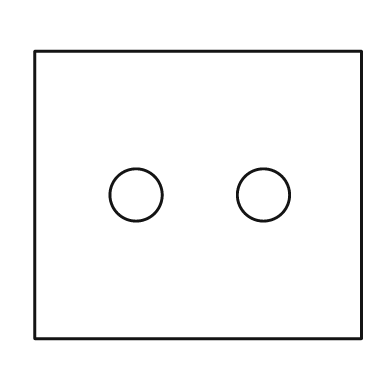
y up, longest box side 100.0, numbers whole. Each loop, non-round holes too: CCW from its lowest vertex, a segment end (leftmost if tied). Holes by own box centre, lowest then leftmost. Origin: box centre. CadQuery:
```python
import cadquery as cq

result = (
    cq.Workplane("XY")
    .moveTo(-50.0, -44.0)
    .lineTo(50.0, -44.0)
    .lineTo(50.0, 44.0)
    .lineTo(-50.0, 44.0)
    .close()
    .moveTo(-19.0, 0.0)
    .circle(8.0)
    .moveTo(20.0, 0.0)
    .circle(8.0)
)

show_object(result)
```